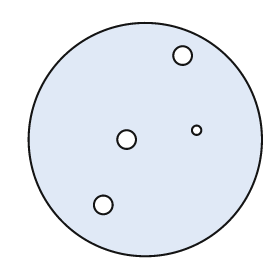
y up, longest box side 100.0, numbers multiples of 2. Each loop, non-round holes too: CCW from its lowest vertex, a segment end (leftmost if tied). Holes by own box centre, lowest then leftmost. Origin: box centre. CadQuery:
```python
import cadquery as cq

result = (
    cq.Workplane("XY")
    .moveTo(0.0, 0.0)
    .circle(50.0)
    .moveTo(-18.0, -28.0)
    .circle(4.0)
    .moveTo(-8.0, 0.0)
    .circle(4.0)
    .moveTo(22.0, 4.0)
    .circle(2.0)
    .moveTo(16.0, 36.0)
    .circle(4.0)
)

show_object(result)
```